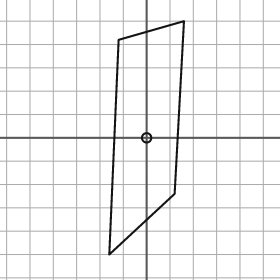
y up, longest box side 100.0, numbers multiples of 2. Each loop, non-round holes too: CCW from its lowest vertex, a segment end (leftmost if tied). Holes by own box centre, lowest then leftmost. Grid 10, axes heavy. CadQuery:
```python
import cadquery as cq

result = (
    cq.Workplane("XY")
    .moveTo(-16.0, -50.0)
    .lineTo(12.0, -24.0)
    .lineTo(16.0, 50.0)
    .lineTo(-12.0, 42.0)
    .close()
    .moveTo(0.0, 0.0)
    .circle(2.0)
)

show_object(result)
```